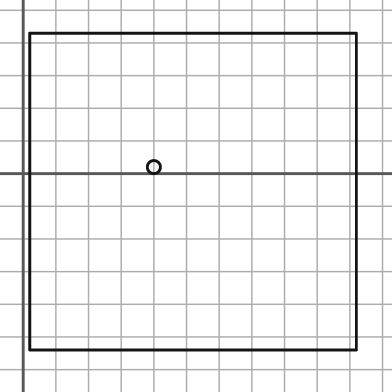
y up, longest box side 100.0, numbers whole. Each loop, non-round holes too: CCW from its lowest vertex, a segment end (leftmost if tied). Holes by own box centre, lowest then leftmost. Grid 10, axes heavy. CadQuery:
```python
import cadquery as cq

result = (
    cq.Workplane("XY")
    .moveTo(2.0, -54.0)
    .lineTo(102.0, -54.0)
    .lineTo(102.0, 43.0)
    .lineTo(2.0, 43.0)
    .close()
    .moveTo(40.0, 2.0)
    .circle(2.0)
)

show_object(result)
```